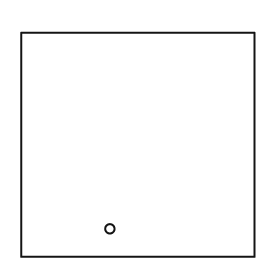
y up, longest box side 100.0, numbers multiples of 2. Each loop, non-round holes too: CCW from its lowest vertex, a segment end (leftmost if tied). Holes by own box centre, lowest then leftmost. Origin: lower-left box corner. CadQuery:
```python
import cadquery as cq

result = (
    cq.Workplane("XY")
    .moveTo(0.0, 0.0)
    .lineTo(100.0, 0.0)
    .lineTo(100.0, 96.0)
    .lineTo(0.0, 96.0)
    .close()
    .moveTo(38.0, 12.0)
    .circle(2.0)
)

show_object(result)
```